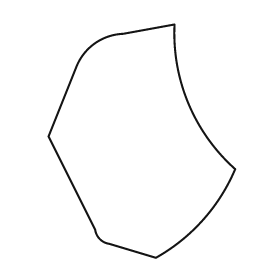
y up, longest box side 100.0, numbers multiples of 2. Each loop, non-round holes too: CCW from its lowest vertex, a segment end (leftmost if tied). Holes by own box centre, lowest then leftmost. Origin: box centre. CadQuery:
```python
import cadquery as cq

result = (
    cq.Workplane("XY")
    .moveTo(6.0, -50.0)
    .threePointArc((26.0, -34.0), (40.0, -12.0))
    .threePointArc((20.0, 16.0), (14.0, 50.0))
    .lineTo(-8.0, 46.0)
    .threePointArc((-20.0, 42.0), (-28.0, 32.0))
    .lineTo(-40.0, 2.0)
    .lineTo(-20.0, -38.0)
    .threePointArc((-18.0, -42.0), (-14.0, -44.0))
    .close()
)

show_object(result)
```